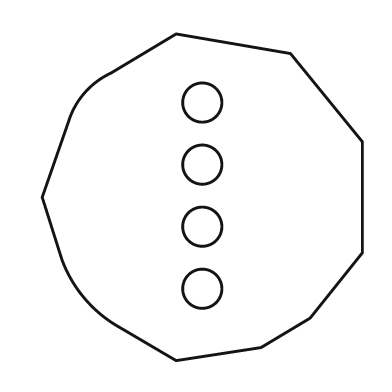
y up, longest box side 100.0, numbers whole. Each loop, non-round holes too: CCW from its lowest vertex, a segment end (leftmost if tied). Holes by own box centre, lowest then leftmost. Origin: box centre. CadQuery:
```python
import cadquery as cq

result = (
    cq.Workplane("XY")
    .moveTo(-8.0, -50.0)
    .lineTo(18.0, -46.0)
    .lineTo(33.0, -37.0)
    .lineTo(49.0, -17.0)
    .lineTo(49.0, 17.0)
    .lineTo(27.0, 44.0)
    .lineTo(-8.0, 50.0)
    .lineTo(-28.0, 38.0)
    .threePointArc((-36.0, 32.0), (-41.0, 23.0))
    .lineTo(-49.0, 0.0)
    .lineTo(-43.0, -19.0)
    .threePointArc((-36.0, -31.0), (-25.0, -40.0))
    .close()
    .moveTo(0.0, -28.0)
    .circle(6.0)
    .moveTo(0.0, -9.0)
    .circle(6.0)
    .moveTo(0.0, 10.0)
    .circle(6.0)
    .moveTo(0.0, 29.0)
    .circle(6.0)
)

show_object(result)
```